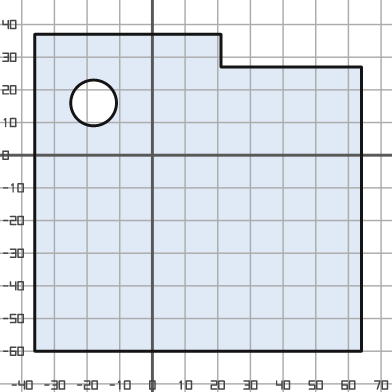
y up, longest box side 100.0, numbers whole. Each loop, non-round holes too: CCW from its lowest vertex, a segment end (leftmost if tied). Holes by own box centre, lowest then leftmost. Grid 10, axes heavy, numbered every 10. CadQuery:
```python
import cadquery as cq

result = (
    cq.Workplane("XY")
    .moveTo(-36.0, -60.0)
    .lineTo(64.0, -60.0)
    .lineTo(64.0, 27.0)
    .lineTo(21.0, 27.0)
    .lineTo(21.0, 37.0)
    .lineTo(-36.0, 37.0)
    .close()
    .moveTo(-18.0, 16.0)
    .circle(7.0)
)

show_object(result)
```